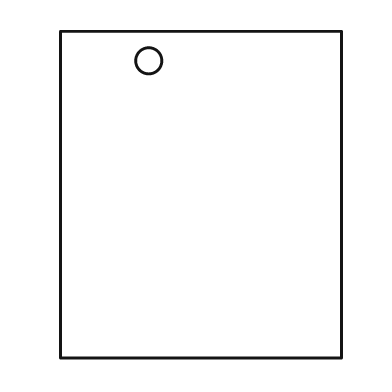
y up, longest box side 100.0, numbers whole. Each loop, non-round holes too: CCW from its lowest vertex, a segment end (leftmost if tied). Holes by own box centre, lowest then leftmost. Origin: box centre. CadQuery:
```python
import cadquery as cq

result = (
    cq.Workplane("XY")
    .moveTo(-43.0, -50.0)
    .lineTo(43.0, -50.0)
    .lineTo(43.0, 50.0)
    .lineTo(-43.0, 50.0)
    .close()
    .moveTo(-16.0, 41.0)
    .circle(4.0)
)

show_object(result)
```